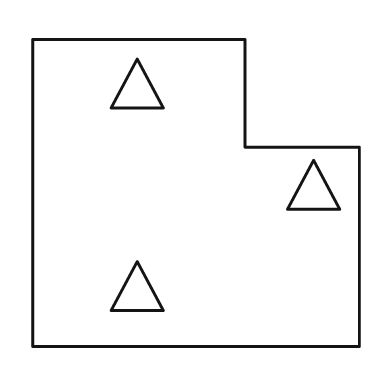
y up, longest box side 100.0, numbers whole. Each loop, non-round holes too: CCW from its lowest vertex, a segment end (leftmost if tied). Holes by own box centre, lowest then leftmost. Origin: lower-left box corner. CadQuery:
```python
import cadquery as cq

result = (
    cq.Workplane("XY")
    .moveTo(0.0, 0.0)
    .lineTo(100.0, 0.0)
    .lineTo(100.0, 61.0)
    .lineTo(65.0, 61.0)
    .lineTo(65.0, 94.0)
    .lineTo(0.0, 94.0)
    .close()
    .moveTo(24.0, 11.0)
    .lineTo(40.0, 11.0)
    .lineTo(32.0, 26.0)
    .close()
    .moveTo(78.0, 42.0)
    .lineTo(94.0, 42.0)
    .lineTo(86.0, 57.0)
    .close()
    .moveTo(24.0, 73.0)
    .lineTo(40.0, 73.0)
    .lineTo(32.0, 88.0)
    .close()
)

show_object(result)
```